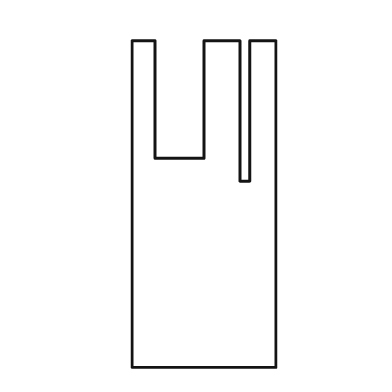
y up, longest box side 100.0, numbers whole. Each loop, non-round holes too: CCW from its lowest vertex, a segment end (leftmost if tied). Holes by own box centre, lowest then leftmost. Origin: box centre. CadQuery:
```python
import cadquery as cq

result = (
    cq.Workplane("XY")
    .moveTo(-22.0, -50.0)
    .lineTo(22.0, -50.0)
    .lineTo(22.0, 50.0)
    .lineTo(14.0, 50.0)
    .lineTo(14.0, 7.0)
    .lineTo(11.0, 7.0)
    .lineTo(11.0, 50.0)
    .lineTo(0.0, 50.0)
    .lineTo(0.0, 14.0)
    .lineTo(-15.0, 14.0)
    .lineTo(-15.0, 50.0)
    .lineTo(-22.0, 50.0)
    .close()
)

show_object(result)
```